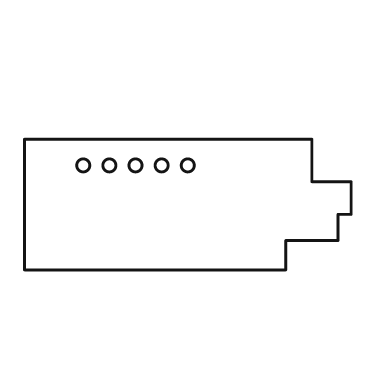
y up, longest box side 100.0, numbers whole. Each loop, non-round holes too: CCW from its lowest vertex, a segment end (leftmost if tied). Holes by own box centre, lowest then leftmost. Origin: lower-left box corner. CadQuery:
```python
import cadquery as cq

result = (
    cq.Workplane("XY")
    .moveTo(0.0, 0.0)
    .lineTo(80.0, 0.0)
    .lineTo(80.0, 9.0)
    .lineTo(96.0, 9.0)
    .lineTo(96.0, 17.0)
    .lineTo(100.0, 17.0)
    .lineTo(100.0, 27.0)
    .lineTo(88.0, 27.0)
    .lineTo(88.0, 40.0)
    .lineTo(0.0, 40.0)
    .close()
    .moveTo(18.0, 32.0)
    .circle(2.0)
    .moveTo(26.0, 32.0)
    .circle(2.0)
    .moveTo(34.0, 32.0)
    .circle(2.0)
    .moveTo(42.0, 32.0)
    .circle(2.0)
    .moveTo(50.0, 32.0)
    .circle(2.0)
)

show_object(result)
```